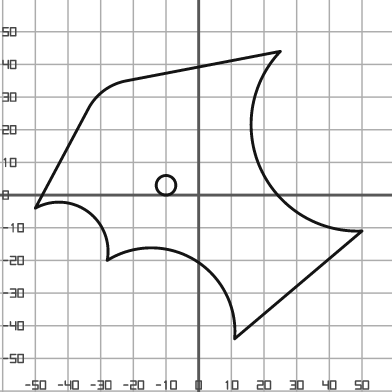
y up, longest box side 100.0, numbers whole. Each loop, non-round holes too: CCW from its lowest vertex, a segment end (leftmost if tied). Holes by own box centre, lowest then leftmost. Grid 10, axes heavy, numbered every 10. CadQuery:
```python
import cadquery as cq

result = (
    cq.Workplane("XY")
    .moveTo(11.0, -44.0)
    .lineTo(50.0, -11.0)
    .threePointArc((19.0, 8.0), (25.0, 44.0))
    .lineTo(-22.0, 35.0)
    .threePointArc((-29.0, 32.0), (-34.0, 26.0))
    .lineTo(-50.0, -4.0)
    .threePointArc((-34.0, -5.0), (-28.0, -20.0))
    .threePointArc((-1.0, -20.0), (11.0, -44.0))
    .close()
    .moveTo(-10.0, 3.0)
    .circle(3.0)
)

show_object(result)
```